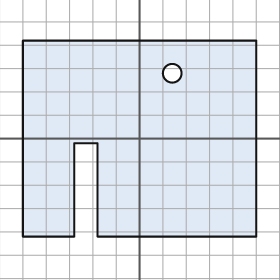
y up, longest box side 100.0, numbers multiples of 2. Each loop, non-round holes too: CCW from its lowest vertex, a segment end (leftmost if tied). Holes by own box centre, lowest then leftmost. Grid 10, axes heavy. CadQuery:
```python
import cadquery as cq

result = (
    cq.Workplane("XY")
    .moveTo(-50.0, -42.0)
    .lineTo(-28.0, -42.0)
    .lineTo(-28.0, -2.0)
    .lineTo(-18.0, -2.0)
    .lineTo(-18.0, -42.0)
    .lineTo(50.0, -42.0)
    .lineTo(50.0, 42.0)
    .lineTo(-50.0, 42.0)
    .close()
    .moveTo(14.0, 28.0)
    .circle(4.0)
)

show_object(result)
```